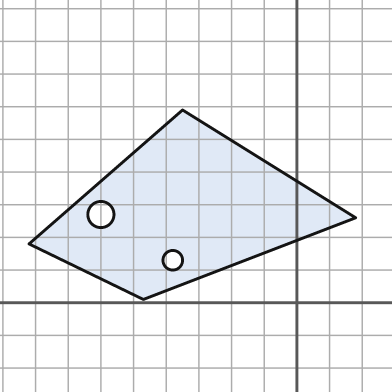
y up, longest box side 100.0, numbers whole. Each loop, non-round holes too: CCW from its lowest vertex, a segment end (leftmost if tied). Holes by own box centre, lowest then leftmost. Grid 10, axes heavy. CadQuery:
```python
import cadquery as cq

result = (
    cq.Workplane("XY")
    .moveTo(-47.0, 1.0)
    .lineTo(18.0, 26.0)
    .lineTo(-35.0, 59.0)
    .lineTo(-82.0, 18.0)
    .close()
    .moveTo(-38.0, 13.0)
    .circle(3.0)
    .moveTo(-60.0, 27.0)
    .circle(4.0)
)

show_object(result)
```